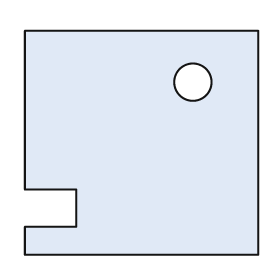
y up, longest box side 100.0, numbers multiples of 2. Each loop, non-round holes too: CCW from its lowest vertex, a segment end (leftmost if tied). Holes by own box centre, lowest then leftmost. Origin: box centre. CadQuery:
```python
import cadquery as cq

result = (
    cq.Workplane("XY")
    .moveTo(-50.0, -48.0)
    .lineTo(50.0, -48.0)
    .lineTo(50.0, 48.0)
    .lineTo(-50.0, 48.0)
    .lineTo(-50.0, -20.0)
    .lineTo(-28.0, -20.0)
    .lineTo(-28.0, -36.0)
    .lineTo(-50.0, -36.0)
    .close()
    .moveTo(22.0, 26.0)
    .circle(8.0)
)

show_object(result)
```